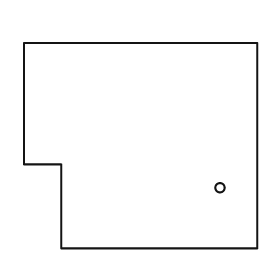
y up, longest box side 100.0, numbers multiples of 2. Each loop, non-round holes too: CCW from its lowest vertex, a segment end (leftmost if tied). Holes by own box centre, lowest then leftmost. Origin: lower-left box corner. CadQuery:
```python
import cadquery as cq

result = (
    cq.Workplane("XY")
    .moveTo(16.0, 0.0)
    .lineTo(100.0, 0.0)
    .lineTo(100.0, 88.0)
    .lineTo(0.0, 88.0)
    .lineTo(0.0, 36.0)
    .lineTo(16.0, 36.0)
    .close()
    .moveTo(84.0, 26.0)
    .circle(2.0)
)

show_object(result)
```